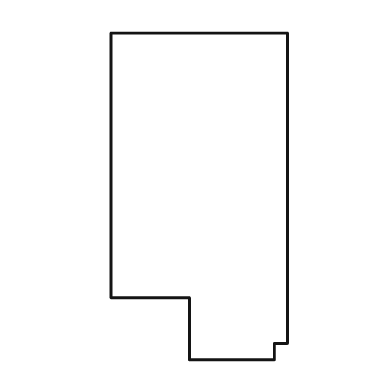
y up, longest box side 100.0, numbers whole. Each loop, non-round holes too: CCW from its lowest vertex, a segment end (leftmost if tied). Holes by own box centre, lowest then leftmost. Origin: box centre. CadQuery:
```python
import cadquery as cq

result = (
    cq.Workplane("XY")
    .moveTo(-3.0, -50.0)
    .lineTo(23.0, -50.0)
    .lineTo(23.0, -45.0)
    .lineTo(27.0, -45.0)
    .lineTo(27.0, 50.0)
    .lineTo(-27.0, 50.0)
    .lineTo(-27.0, -31.0)
    .lineTo(-3.0, -31.0)
    .close()
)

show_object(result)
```